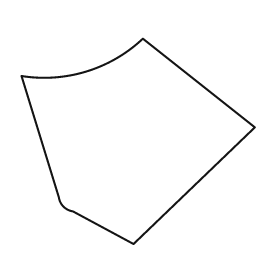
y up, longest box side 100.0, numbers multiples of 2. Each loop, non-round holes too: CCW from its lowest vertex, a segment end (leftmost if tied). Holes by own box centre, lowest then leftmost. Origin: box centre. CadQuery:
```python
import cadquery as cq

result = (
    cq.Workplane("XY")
    .moveTo(-2.0, -44.0)
    .lineTo(50.0, 6.0)
    .lineTo(2.0, 44.0)
    .threePointArc((-22.0, 30.0), (-50.0, 28.0))
    .lineTo(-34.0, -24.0)
    .threePointArc((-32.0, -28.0), (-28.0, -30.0))
    .close()
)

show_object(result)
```